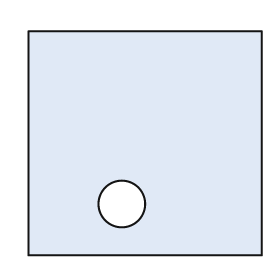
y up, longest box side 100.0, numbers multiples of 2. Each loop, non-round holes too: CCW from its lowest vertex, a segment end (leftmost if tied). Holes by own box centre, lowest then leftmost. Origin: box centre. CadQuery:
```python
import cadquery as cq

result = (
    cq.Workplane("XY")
    .moveTo(-50.0, -48.0)
    .lineTo(50.0, -48.0)
    .lineTo(50.0, 48.0)
    .lineTo(-50.0, 48.0)
    .close()
    .moveTo(-10.0, -26.0)
    .circle(10.0)
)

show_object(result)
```